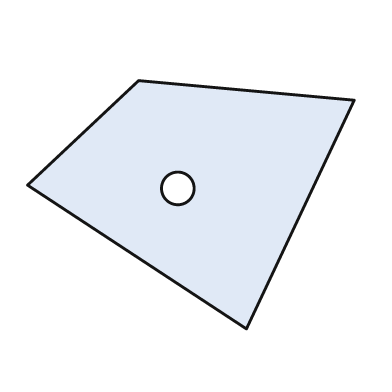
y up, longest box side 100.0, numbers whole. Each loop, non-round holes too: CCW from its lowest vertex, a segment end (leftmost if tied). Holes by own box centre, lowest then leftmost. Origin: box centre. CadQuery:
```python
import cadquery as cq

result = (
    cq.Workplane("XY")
    .moveTo(17.0, -38.0)
    .lineTo(50.0, 32.0)
    .lineTo(-16.0, 38.0)
    .lineTo(-50.0, 6.0)
    .close()
    .moveTo(-4.0, 5.0)
    .circle(5.0)
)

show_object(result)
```